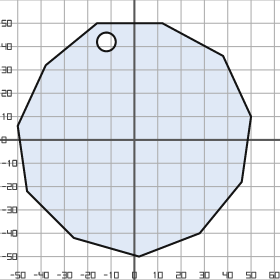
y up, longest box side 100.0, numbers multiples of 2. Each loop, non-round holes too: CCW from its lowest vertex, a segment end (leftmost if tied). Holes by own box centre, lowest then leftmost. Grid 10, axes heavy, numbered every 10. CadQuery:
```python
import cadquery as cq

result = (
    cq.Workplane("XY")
    .moveTo(2.0, -50.0)
    .lineTo(28.0, -40.0)
    .lineTo(46.0, -18.0)
    .lineTo(50.0, 10.0)
    .lineTo(38.0, 36.0)
    .lineTo(12.0, 50.0)
    .lineTo(-16.0, 50.0)
    .lineTo(-38.0, 32.0)
    .lineTo(-50.0, 6.0)
    .lineTo(-46.0, -22.0)
    .lineTo(-26.0, -42.0)
    .close()
    .moveTo(-12.0, 42.0)
    .circle(4.0)
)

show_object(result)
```